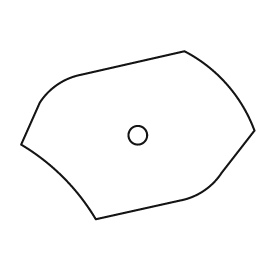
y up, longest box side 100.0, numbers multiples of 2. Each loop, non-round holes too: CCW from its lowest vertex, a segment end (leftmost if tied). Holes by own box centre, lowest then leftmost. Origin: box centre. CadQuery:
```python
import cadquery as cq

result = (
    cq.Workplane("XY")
    .moveTo(-18.0, -36.0)
    .lineTo(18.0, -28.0)
    .threePointArc((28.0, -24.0), (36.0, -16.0))
    .lineTo(50.0, 2.0)
    .threePointArc((38.0, 22.0), (20.0, 36.0))
    .lineTo(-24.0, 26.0)
    .threePointArc((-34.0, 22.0), (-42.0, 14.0))
    .lineTo(-50.0, -4.0)
    .threePointArc((-32.0, -18.0), (-18.0, -36.0))
    .close()
    .moveTo(0.0, 0.0)
    .circle(4.0)
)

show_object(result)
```